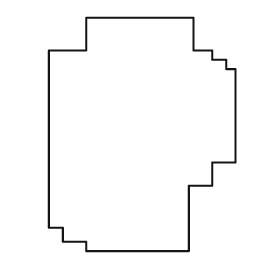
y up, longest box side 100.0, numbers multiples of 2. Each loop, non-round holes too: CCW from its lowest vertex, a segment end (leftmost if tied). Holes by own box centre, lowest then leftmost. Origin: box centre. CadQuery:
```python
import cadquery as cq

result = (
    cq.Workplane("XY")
    .moveTo(-24.0, -50.0)
    .lineTo(20.0, -50.0)
    .lineTo(20.0, -22.0)
    .lineTo(30.0, -22.0)
    .lineTo(30.0, -12.0)
    .lineTo(40.0, -12.0)
    .lineTo(40.0, 28.0)
    .lineTo(36.0, 28.0)
    .lineTo(36.0, 32.0)
    .lineTo(30.0, 32.0)
    .lineTo(30.0, 36.0)
    .lineTo(22.0, 36.0)
    .lineTo(22.0, 50.0)
    .lineTo(-24.0, 50.0)
    .lineTo(-24.0, 36.0)
    .lineTo(-40.0, 36.0)
    .lineTo(-40.0, -40.0)
    .lineTo(-34.0, -40.0)
    .lineTo(-34.0, -46.0)
    .lineTo(-24.0, -46.0)
    .close()
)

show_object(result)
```